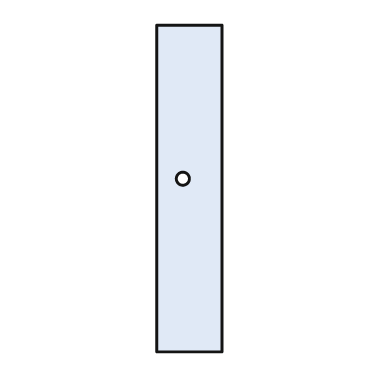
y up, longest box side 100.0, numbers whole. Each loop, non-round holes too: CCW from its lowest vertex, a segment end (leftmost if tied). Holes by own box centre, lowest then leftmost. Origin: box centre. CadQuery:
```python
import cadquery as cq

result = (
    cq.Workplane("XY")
    .moveTo(-10.0, -50.0)
    .lineTo(10.0, -50.0)
    .lineTo(10.0, 50.0)
    .lineTo(-10.0, 50.0)
    .close()
    .moveTo(-2.0, 3.0)
    .circle(2.0)
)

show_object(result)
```